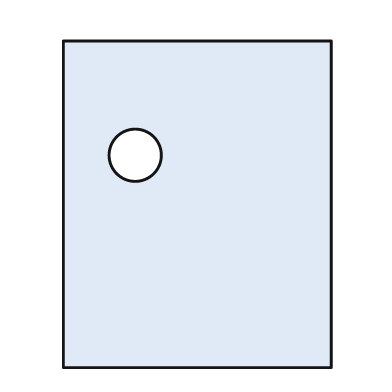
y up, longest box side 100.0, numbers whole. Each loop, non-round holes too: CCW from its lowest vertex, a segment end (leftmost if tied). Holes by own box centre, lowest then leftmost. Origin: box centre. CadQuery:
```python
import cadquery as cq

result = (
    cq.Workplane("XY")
    .moveTo(-41.0, -50.0)
    .lineTo(41.0, -50.0)
    .lineTo(41.0, 50.0)
    .lineTo(-41.0, 50.0)
    .close()
    .moveTo(-19.0, 15.0)
    .circle(8.0)
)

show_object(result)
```